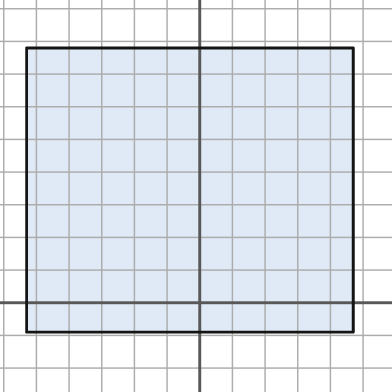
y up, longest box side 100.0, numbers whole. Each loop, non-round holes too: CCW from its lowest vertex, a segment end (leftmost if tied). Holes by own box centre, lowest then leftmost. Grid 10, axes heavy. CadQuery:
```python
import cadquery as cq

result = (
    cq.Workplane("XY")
    .moveTo(-53.0, -9.0)
    .lineTo(47.0, -9.0)
    .lineTo(47.0, 78.0)
    .lineTo(-53.0, 78.0)
    .close()
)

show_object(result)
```